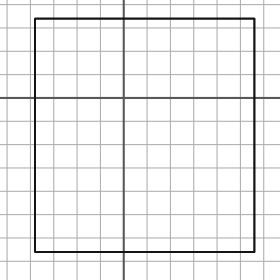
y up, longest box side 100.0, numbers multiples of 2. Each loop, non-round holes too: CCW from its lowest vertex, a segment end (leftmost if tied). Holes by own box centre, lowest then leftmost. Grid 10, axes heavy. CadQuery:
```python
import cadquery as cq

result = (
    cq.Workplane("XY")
    .moveTo(-38.0, -66.0)
    .lineTo(56.0, -66.0)
    .lineTo(56.0, 34.0)
    .lineTo(-38.0, 34.0)
    .close()
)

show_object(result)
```